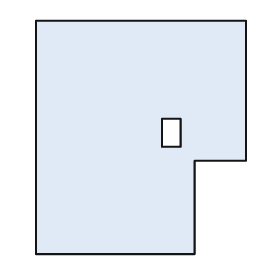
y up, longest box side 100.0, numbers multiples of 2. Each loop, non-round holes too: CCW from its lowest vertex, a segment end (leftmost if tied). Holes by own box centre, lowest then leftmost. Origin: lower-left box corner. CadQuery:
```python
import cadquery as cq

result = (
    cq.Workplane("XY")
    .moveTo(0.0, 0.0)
    .lineTo(68.0, 0.0)
    .lineTo(68.0, 40.0)
    .lineTo(90.0, 40.0)
    .lineTo(90.0, 100.0)
    .lineTo(0.0, 100.0)
    .close()
    .moveTo(54.0, 46.0)
    .lineTo(62.0, 46.0)
    .lineTo(62.0, 58.0)
    .lineTo(54.0, 58.0)
    .close()
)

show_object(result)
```